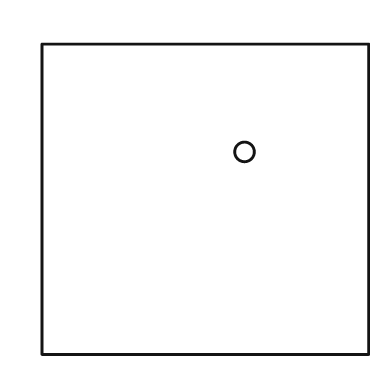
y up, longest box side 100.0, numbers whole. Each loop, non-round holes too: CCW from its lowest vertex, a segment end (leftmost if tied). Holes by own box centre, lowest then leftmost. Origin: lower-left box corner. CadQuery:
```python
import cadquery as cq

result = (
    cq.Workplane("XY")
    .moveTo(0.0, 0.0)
    .lineTo(100.0, 0.0)
    .lineTo(100.0, 95.0)
    .lineTo(0.0, 95.0)
    .close()
    .moveTo(62.0, 62.0)
    .circle(3.0)
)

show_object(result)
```